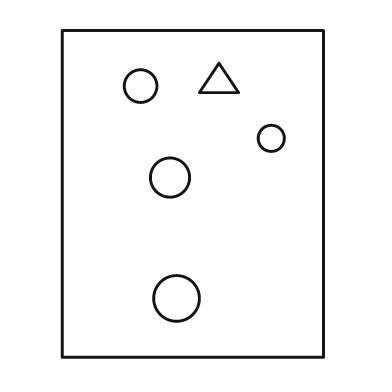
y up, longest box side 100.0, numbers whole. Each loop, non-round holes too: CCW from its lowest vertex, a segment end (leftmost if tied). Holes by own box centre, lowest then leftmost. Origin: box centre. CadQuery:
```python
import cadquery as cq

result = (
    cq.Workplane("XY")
    .moveTo(-40.0, -50.0)
    .lineTo(40.0, -50.0)
    .lineTo(40.0, 50.0)
    .lineTo(-40.0, 50.0)
    .close()
    .moveTo(-5.0, -32.0)
    .circle(7.0)
    .moveTo(-7.0, 5.0)
    .circle(6.0)
    .moveTo(24.0, 17.0)
    .circle(4.0)
    .moveTo(-16.0, 33.0)
    .circle(5.0)
    .moveTo(2.0, 31.0)
    .lineTo(14.0, 31.0)
    .lineTo(8.0, 40.0)
    .close()
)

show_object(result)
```